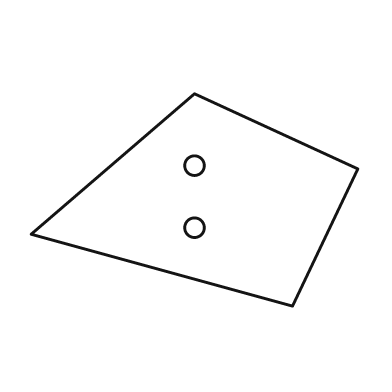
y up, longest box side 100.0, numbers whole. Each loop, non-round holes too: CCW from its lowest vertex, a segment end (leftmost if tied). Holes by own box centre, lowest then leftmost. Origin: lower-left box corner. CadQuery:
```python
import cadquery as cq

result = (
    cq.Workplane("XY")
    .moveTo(80.0, 0.0)
    .lineTo(100.0, 42.0)
    .lineTo(50.0, 65.0)
    .lineTo(0.0, 22.0)
    .close()
    .moveTo(50.0, 24.0)
    .circle(3.0)
    .moveTo(50.0, 43.0)
    .circle(3.0)
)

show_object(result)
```